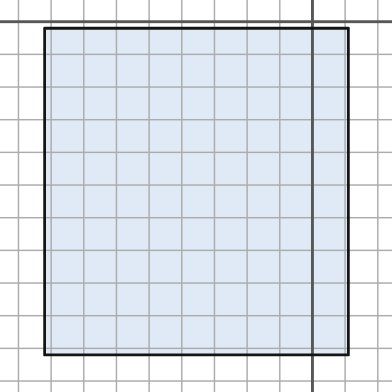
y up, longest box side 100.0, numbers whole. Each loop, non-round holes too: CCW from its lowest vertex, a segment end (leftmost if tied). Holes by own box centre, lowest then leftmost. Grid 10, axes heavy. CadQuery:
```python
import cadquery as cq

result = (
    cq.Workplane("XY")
    .moveTo(-82.0, -102.0)
    .lineTo(11.0, -102.0)
    .lineTo(11.0, -2.0)
    .lineTo(-82.0, -2.0)
    .close()
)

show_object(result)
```